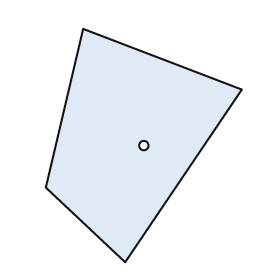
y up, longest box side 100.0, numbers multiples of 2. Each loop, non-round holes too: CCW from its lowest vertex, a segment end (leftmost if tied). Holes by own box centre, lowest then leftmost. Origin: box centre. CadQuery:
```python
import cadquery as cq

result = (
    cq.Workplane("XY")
    .moveTo(-8.0, -50.0)
    .lineTo(42.0, 24.0)
    .lineTo(-26.0, 50.0)
    .lineTo(-42.0, -18.0)
    .close()
    .moveTo(0.0, 0.0)
    .circle(2.0)
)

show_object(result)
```